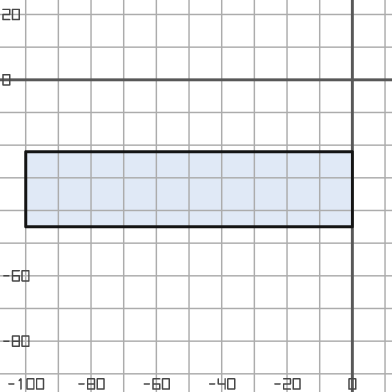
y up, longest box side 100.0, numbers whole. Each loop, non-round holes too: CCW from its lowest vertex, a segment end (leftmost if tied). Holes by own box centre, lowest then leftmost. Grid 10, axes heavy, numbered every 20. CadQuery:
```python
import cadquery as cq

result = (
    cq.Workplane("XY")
    .moveTo(-100.0, -45.0)
    .lineTo(0.0, -45.0)
    .lineTo(0.0, -22.0)
    .lineTo(-100.0, -22.0)
    .close()
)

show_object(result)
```